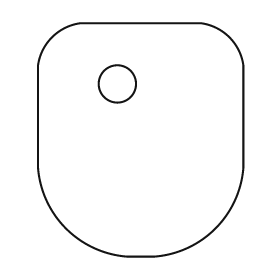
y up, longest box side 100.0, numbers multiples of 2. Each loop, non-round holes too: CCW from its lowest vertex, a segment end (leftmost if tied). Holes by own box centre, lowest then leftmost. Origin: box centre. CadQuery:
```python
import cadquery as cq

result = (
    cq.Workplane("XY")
    .moveTo(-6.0, -50.0)
    .lineTo(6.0, -50.0)
    .threePointArc((32.0, -38.0), (44.0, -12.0))
    .lineTo(44.0, 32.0)
    .threePointArc((38.0, 44.0), (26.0, 50.0))
    .lineTo(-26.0, 50.0)
    .threePointArc((-38.0, 44.0), (-44.0, 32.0))
    .lineTo(-44.0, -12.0)
    .threePointArc((-32.0, -38.0), (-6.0, -50.0))
    .close()
    .moveTo(-10.0, 24.0)
    .circle(8.0)
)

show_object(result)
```